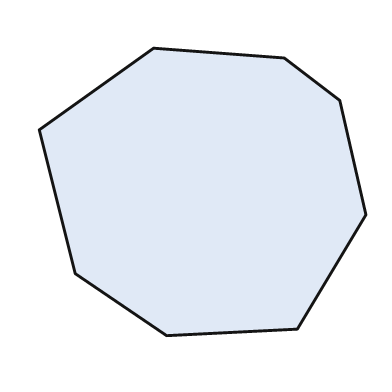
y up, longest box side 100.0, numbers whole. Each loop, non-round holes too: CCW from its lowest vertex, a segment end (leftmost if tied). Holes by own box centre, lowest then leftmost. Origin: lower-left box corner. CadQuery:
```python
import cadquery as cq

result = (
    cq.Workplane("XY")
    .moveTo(39.0, 0.0)
    .lineTo(79.0, 2.0)
    .lineTo(100.0, 37.0)
    .lineTo(92.0, 72.0)
    .lineTo(75.0, 85.0)
    .lineTo(35.0, 88.0)
    .lineTo(0.0, 63.0)
    .lineTo(11.0, 19.0)
    .close()
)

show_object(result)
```